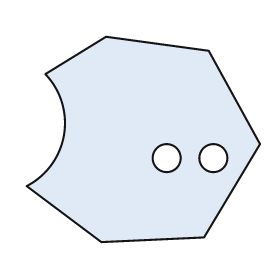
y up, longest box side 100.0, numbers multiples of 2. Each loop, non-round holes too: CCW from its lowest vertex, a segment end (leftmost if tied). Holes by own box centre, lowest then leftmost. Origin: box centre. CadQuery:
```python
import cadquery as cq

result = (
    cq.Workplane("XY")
    .moveTo(-18.0, -44.0)
    .lineTo(26.0, -42.0)
    .lineTo(50.0, -2.0)
    .lineTo(28.0, 38.0)
    .lineTo(-16.0, 44.0)
    .lineTo(-42.0, 28.0)
    .threePointArc((-34.0, 2.0), (-50.0, -20.0))
    .close()
    .moveTo(10.0, -8.0)
    .circle(6.0)
    .moveTo(30.0, -8.0)
    .circle(6.0)
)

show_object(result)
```